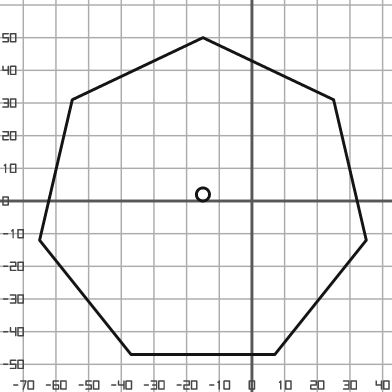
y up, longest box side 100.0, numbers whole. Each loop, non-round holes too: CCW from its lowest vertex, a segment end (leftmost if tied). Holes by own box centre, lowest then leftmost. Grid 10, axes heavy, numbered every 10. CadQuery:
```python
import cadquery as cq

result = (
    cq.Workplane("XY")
    .moveTo(-37.0, -47.0)
    .lineTo(7.0, -47.0)
    .lineTo(35.0, -12.0)
    .lineTo(25.0, 31.0)
    .lineTo(-15.0, 50.0)
    .lineTo(-55.0, 31.0)
    .lineTo(-65.0, -12.0)
    .close()
    .moveTo(-15.0, 2.0)
    .circle(2.0)
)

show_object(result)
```